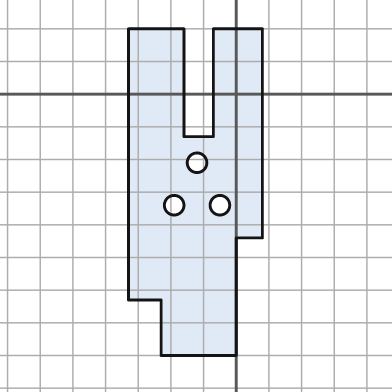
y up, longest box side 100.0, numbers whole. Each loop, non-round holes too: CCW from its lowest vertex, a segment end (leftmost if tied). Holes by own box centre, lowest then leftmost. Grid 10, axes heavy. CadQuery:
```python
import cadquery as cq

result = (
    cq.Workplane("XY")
    .moveTo(-23.0, -80.0)
    .lineTo(0.0, -80.0)
    .lineTo(0.0, -44.0)
    .lineTo(8.0, -44.0)
    .lineTo(8.0, 20.0)
    .lineTo(-7.0, 20.0)
    .lineTo(-7.0, -13.0)
    .lineTo(-16.0, -13.0)
    .lineTo(-16.0, 20.0)
    .lineTo(-33.0, 20.0)
    .lineTo(-33.0, -63.0)
    .lineTo(-23.0, -63.0)
    .close()
    .moveTo(-19.0, -34.0)
    .circle(3.0)
    .moveTo(-5.0, -34.0)
    .circle(3.0)
    .moveTo(-12.0, -21.0)
    .circle(3.0)
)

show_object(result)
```